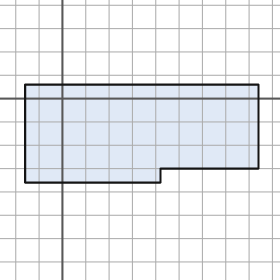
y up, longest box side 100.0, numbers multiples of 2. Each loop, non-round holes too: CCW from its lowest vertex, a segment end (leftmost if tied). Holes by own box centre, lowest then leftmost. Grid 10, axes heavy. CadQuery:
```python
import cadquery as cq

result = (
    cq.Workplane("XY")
    .moveTo(-16.0, -36.0)
    .lineTo(42.0, -36.0)
    .lineTo(42.0, -30.0)
    .lineTo(84.0, -30.0)
    .lineTo(84.0, 6.0)
    .lineTo(-16.0, 6.0)
    .close()
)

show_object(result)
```